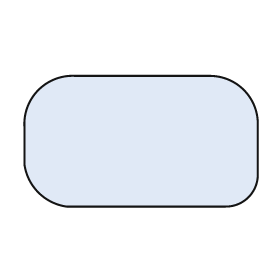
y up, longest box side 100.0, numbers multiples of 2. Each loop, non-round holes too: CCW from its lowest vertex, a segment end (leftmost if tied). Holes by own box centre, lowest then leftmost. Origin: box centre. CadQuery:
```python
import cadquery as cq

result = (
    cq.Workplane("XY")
    .moveTo(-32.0, -28.0)
    .lineTo(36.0, -28.0)
    .threePointArc((46.0, -24.0), (50.0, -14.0))
    .lineTo(50.0, 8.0)
    .threePointArc((44.0, 22.0), (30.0, 28.0))
    .lineTo(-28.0, 28.0)
    .threePointArc((-44.0, 22.0), (-50.0, 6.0))
    .lineTo(-50.0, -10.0)
    .threePointArc((-44.0, -22.0), (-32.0, -28.0))
    .close()
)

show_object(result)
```